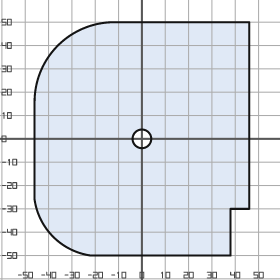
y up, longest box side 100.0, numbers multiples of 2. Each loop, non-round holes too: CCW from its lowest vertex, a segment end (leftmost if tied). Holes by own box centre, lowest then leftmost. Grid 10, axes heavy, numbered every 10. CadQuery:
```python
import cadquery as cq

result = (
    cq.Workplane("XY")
    .moveTo(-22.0, -50.0)
    .lineTo(38.0, -50.0)
    .lineTo(38.0, -30.0)
    .lineTo(46.0, -30.0)
    .lineTo(46.0, 50.0)
    .lineTo(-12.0, 50.0)
    .threePointArc((-36.0, 40.0), (-46.0, 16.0))
    .lineTo(-46.0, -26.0)
    .threePointArc((-38.0, -42.0), (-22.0, -50.0))
    .close()
    .moveTo(0.0, 0.0)
    .circle(4.0)
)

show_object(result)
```